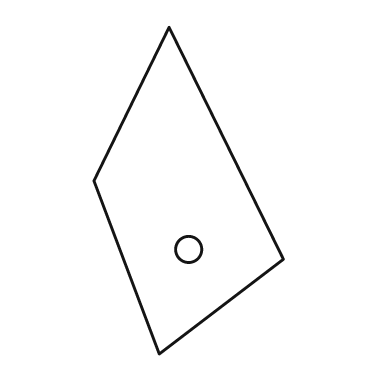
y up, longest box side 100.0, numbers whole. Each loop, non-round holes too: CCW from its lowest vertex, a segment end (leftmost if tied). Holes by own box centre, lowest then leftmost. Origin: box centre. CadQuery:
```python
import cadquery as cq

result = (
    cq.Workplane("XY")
    .moveTo(-9.0, -50.0)
    .lineTo(29.0, -21.0)
    .lineTo(-6.0, 50.0)
    .lineTo(-29.0, 3.0)
    .close()
    .moveTo(0.0, -18.0)
    .circle(4.0)
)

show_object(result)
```